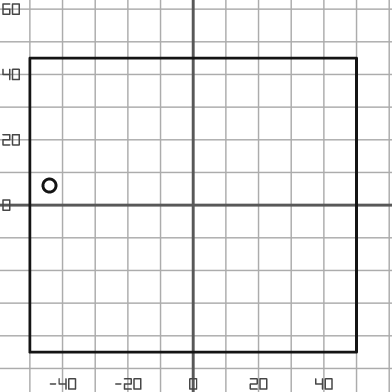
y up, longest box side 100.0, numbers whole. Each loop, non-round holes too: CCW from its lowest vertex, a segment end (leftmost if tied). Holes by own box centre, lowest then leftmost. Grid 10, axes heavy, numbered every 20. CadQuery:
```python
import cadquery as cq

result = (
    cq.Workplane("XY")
    .moveTo(-50.0, -45.0)
    .lineTo(50.0, -45.0)
    .lineTo(50.0, 45.0)
    .lineTo(-50.0, 45.0)
    .close()
    .moveTo(-44.0, 6.0)
    .circle(2.0)
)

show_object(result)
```